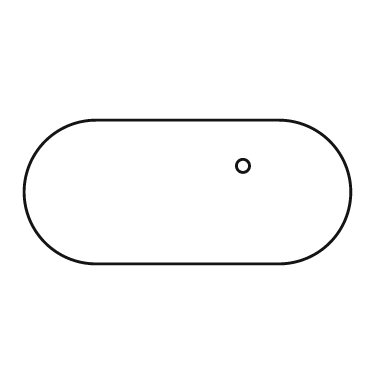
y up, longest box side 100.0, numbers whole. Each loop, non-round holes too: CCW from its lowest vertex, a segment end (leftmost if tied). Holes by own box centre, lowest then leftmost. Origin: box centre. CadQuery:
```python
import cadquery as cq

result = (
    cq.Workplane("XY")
    .moveTo(-28.0, -22.0)
    .lineTo(28.0, -22.0)
    .threePointArc((50.0, 0.0), (28.0, 22.0))
    .lineTo(-28.0, 22.0)
    .threePointArc((-50.0, 0.0), (-28.0, -22.0))
    .close()
    .moveTo(17.0, 8.0)
    .circle(2.0)
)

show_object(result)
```